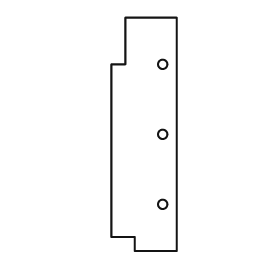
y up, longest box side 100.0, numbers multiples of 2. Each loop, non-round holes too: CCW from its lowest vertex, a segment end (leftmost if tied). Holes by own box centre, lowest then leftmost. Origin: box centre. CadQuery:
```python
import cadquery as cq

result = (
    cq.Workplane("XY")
    .moveTo(-4.0, -50.0)
    .lineTo(14.0, -50.0)
    .lineTo(14.0, 50.0)
    .lineTo(-8.0, 50.0)
    .lineTo(-8.0, 30.0)
    .lineTo(-14.0, 30.0)
    .lineTo(-14.0, -44.0)
    .lineTo(-4.0, -44.0)
    .close()
    .moveTo(8.0, -30.0)
    .circle(2.0)
    .moveTo(8.0, 0.0)
    .circle(2.0)
    .moveTo(8.0, 30.0)
    .circle(2.0)
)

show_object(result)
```